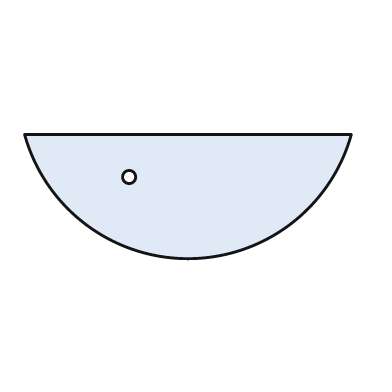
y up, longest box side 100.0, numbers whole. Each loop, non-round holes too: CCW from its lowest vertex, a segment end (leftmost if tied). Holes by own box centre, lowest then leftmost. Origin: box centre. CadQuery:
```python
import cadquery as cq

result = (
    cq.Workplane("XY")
    .moveTo(-50.0, 19.0)
    .threePointArc((0.0, -19.0), (50.0, 19.0))
    .close()
    .moveTo(-18.0, 6.0)
    .circle(2.0)
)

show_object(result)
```